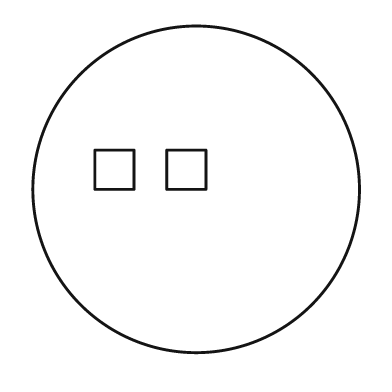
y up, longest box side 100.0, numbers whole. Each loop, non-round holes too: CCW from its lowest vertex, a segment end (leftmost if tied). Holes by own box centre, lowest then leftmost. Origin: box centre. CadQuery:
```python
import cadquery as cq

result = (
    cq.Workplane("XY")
    .moveTo(0.0, 0.0)
    .circle(50.0)
    .moveTo(-31.0, 0.0)
    .lineTo(-19.0, 0.0)
    .lineTo(-19.0, 12.0)
    .lineTo(-31.0, 12.0)
    .close()
    .moveTo(-9.0, 0.0)
    .lineTo(3.0, 0.0)
    .lineTo(3.0, 12.0)
    .lineTo(-9.0, 12.0)
    .close()
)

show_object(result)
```